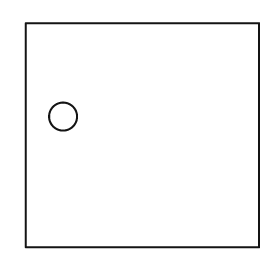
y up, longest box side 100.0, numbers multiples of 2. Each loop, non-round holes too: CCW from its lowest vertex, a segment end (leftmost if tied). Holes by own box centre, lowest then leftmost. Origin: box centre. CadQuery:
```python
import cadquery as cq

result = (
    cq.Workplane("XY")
    .moveTo(-50.0, -48.0)
    .lineTo(50.0, -48.0)
    .lineTo(50.0, 48.0)
    .lineTo(-50.0, 48.0)
    .close()
    .moveTo(-34.0, 8.0)
    .circle(6.0)
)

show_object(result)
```